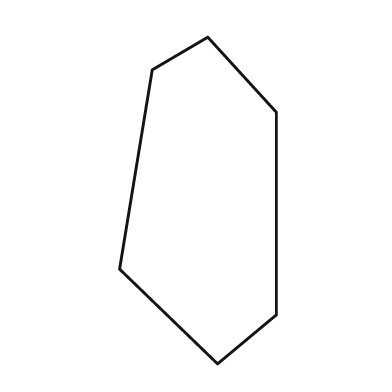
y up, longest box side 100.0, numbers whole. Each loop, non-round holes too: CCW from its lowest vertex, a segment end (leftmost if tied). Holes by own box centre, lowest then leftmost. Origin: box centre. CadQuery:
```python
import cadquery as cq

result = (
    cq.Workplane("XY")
    .moveTo(6.0, -50.0)
    .lineTo(24.0, -35.0)
    .lineTo(24.0, 27.0)
    .lineTo(3.0, 50.0)
    .lineTo(-14.0, 40.0)
    .lineTo(-24.0, -21.0)
    .close()
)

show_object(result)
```